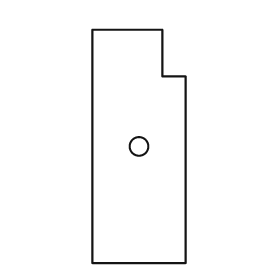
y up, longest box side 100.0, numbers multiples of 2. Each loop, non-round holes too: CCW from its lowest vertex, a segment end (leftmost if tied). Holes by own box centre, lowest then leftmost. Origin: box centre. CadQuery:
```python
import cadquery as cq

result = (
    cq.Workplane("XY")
    .moveTo(-20.0, -50.0)
    .lineTo(20.0, -50.0)
    .lineTo(20.0, 30.0)
    .lineTo(10.0, 30.0)
    .lineTo(10.0, 50.0)
    .lineTo(-20.0, 50.0)
    .close()
    .moveTo(0.0, 0.0)
    .circle(4.0)
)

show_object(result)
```